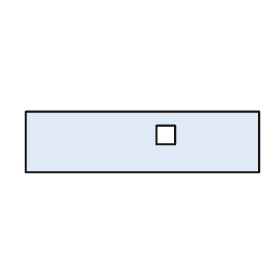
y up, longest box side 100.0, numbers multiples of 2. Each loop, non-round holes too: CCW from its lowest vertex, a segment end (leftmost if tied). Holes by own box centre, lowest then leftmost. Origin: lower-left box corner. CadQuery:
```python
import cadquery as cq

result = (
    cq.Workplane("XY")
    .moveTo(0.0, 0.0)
    .lineTo(100.0, 0.0)
    .lineTo(100.0, 26.0)
    .lineTo(0.0, 26.0)
    .close()
    .moveTo(56.0, 12.0)
    .lineTo(64.0, 12.0)
    .lineTo(64.0, 20.0)
    .lineTo(56.0, 20.0)
    .close()
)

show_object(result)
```